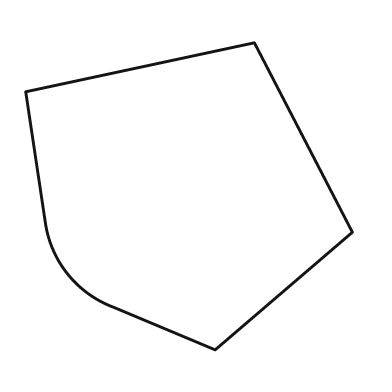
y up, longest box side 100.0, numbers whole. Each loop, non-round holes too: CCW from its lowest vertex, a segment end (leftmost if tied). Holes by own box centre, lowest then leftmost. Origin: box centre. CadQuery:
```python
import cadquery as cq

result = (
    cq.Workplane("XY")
    .moveTo(8.0, -47.0)
    .lineTo(50.0, -11.0)
    .lineTo(20.0, 47.0)
    .lineTo(-50.0, 32.0)
    .lineTo(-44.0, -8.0)
    .threePointArc((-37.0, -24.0), (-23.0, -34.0))
    .close()
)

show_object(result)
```